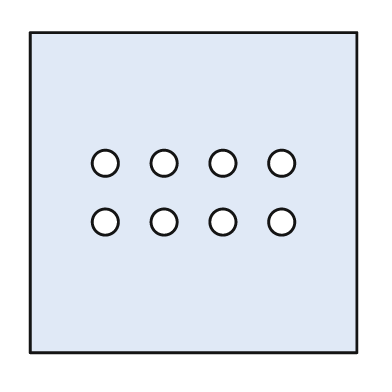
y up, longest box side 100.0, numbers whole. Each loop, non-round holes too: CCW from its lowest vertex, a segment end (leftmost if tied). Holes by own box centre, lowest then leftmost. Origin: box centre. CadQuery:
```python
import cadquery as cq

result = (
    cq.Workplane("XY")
    .moveTo(-50.0, -49.0)
    .lineTo(50.0, -49.0)
    .lineTo(50.0, 49.0)
    .lineTo(-50.0, 49.0)
    .close()
    .moveTo(-27.0, -9.0)
    .circle(4.0)
    .moveTo(-9.0, -9.0)
    .circle(4.0)
    .moveTo(9.0, -9.0)
    .circle(4.0)
    .moveTo(27.0, -9.0)
    .circle(4.0)
    .moveTo(-27.0, 9.0)
    .circle(4.0)
    .moveTo(-9.0, 9.0)
    .circle(4.0)
    .moveTo(9.0, 9.0)
    .circle(4.0)
    .moveTo(27.0, 9.0)
    .circle(4.0)
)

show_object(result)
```